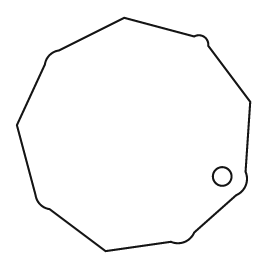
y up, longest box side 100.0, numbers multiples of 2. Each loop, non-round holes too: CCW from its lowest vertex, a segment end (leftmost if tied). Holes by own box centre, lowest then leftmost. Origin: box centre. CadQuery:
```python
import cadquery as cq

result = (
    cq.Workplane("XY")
    .moveTo(-12.0, -50.0)
    .lineTo(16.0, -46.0)
    .threePointArc((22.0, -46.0), (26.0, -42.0))
    .lineTo(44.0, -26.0)
    .threePointArc((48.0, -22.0), (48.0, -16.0))
    .lineTo(50.0, 14.0)
    .lineTo(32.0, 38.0)
    .threePointArc((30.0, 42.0), (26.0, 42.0))
    .lineTo(-4.0, 50.0)
    .lineTo(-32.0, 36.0)
    .threePointArc((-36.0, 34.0), (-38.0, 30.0))
    .lineTo(-50.0, 4.0)
    .lineTo(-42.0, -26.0)
    .threePointArc((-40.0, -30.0), (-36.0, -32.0))
    .close()
    .moveTo(38.0, -18.0)
    .circle(4.0)
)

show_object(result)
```